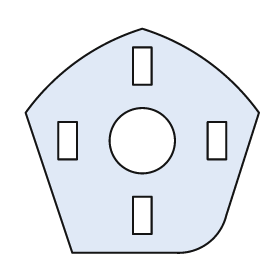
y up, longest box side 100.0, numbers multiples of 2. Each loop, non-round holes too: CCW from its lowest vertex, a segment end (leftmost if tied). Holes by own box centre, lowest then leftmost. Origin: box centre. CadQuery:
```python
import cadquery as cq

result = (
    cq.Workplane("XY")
    .moveTo(-30.0, -48.0)
    .lineTo(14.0, -48.0)
    .threePointArc((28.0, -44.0), (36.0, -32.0))
    .lineTo(50.0, 12.0)
    .threePointArc((28.0, 34.0), (0.0, 48.0))
    .threePointArc((-28.0, 34.0), (-50.0, 12.0))
    .close()
    .moveTo(-4.0, -40.0)
    .lineTo(4.0, -40.0)
    .lineTo(4.0, -24.0)
    .lineTo(-4.0, -24.0)
    .close()
    .moveTo(-36.0, -8.0)
    .lineTo(-28.0, -8.0)
    .lineTo(-28.0, 8.0)
    .lineTo(-36.0, 8.0)
    .close()
    .moveTo(0.0, 0.0)
    .circle(14.0)
    .moveTo(28.0, -8.0)
    .lineTo(36.0, -8.0)
    .lineTo(36.0, 8.0)
    .lineTo(28.0, 8.0)
    .close()
    .moveTo(-4.0, 24.0)
    .lineTo(4.0, 24.0)
    .lineTo(4.0, 40.0)
    .lineTo(-4.0, 40.0)
    .close()
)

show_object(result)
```